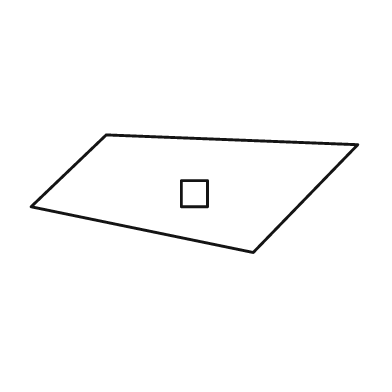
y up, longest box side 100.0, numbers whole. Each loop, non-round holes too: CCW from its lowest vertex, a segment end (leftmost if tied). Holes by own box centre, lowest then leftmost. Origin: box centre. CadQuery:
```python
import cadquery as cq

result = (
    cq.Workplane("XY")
    .moveTo(18.0, -18.0)
    .lineTo(50.0, 15.0)
    .lineTo(-27.0, 18.0)
    .lineTo(-50.0, -4.0)
    .close()
    .moveTo(-4.0, -4.0)
    .lineTo(4.0, -4.0)
    .lineTo(4.0, 4.0)
    .lineTo(-4.0, 4.0)
    .close()
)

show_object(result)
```